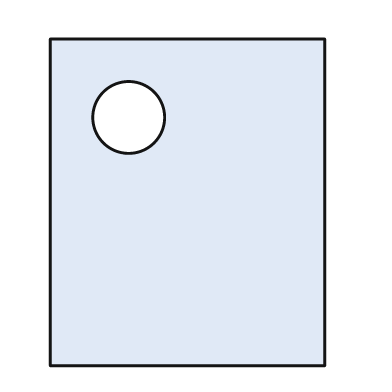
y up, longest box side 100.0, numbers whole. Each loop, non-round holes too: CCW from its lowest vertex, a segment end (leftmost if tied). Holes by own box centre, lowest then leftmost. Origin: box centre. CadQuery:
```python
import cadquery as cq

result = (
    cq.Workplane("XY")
    .moveTo(-42.0, -50.0)
    .lineTo(42.0, -50.0)
    .lineTo(42.0, 50.0)
    .lineTo(-42.0, 50.0)
    .close()
    .moveTo(-18.0, 26.0)
    .circle(11.0)
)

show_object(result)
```